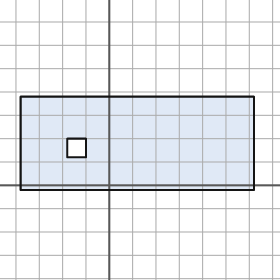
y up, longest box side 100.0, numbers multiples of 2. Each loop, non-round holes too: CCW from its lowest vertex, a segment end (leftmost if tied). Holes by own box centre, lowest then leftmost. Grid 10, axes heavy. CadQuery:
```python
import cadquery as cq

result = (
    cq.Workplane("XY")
    .moveTo(-38.0, -2.0)
    .lineTo(62.0, -2.0)
    .lineTo(62.0, 38.0)
    .lineTo(-38.0, 38.0)
    .close()
    .moveTo(-18.0, 12.0)
    .lineTo(-10.0, 12.0)
    .lineTo(-10.0, 20.0)
    .lineTo(-18.0, 20.0)
    .close()
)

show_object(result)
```